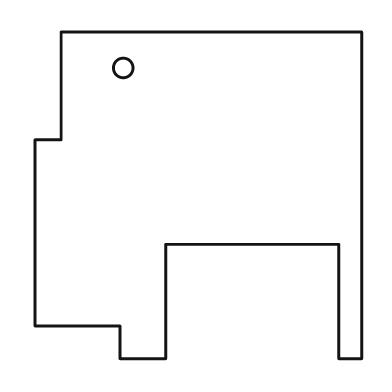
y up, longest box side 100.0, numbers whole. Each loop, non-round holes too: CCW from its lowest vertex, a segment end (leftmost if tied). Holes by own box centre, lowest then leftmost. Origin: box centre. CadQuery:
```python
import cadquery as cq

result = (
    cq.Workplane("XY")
    .moveTo(-24.0, -50.0)
    .lineTo(-10.0, -50.0)
    .lineTo(-10.0, -15.0)
    .lineTo(43.0, -15.0)
    .lineTo(43.0, -50.0)
    .lineTo(50.0, -50.0)
    .lineTo(50.0, 50.0)
    .lineTo(-42.0, 50.0)
    .lineTo(-42.0, 17.0)
    .lineTo(-50.0, 17.0)
    .lineTo(-50.0, -40.0)
    .lineTo(-24.0, -40.0)
    .close()
    .moveTo(-23.0, 39.0)
    .circle(3.0)
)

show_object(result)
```